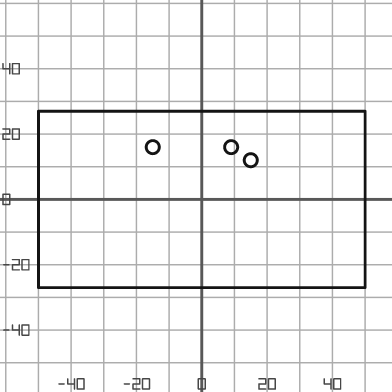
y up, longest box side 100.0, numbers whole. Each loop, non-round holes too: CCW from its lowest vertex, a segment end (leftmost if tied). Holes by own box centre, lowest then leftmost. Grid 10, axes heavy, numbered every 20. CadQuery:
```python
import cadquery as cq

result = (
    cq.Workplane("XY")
    .moveTo(-50.0, -27.0)
    .lineTo(50.0, -27.0)
    .lineTo(50.0, 27.0)
    .lineTo(-50.0, 27.0)
    .close()
    .moveTo(15.0, 12.0)
    .circle(2.0)
    .moveTo(-15.0, 16.0)
    .circle(2.0)
    .moveTo(9.0, 16.0)
    .circle(2.0)
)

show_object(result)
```